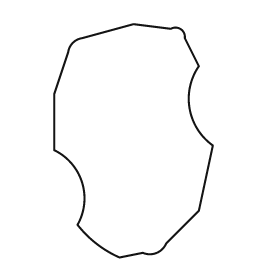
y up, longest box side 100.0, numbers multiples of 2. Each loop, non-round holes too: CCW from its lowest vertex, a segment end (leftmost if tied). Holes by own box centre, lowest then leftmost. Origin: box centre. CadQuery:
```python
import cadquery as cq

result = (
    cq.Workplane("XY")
    .moveTo(-6.0, -50.0)
    .lineTo(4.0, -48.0)
    .threePointArc((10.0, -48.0), (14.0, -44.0))
    .lineTo(28.0, -30.0)
    .lineTo(34.0, -2.0)
    .threePointArc((24.0, 14.0), (28.0, 32.0))
    .lineTo(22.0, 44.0)
    .threePointArc((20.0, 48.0), (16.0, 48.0))
    .lineTo(0.0, 50.0)
    .lineTo(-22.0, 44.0)
    .threePointArc((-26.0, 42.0), (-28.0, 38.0))
    .lineTo(-34.0, 20.0)
    .lineTo(-34.0, -4.0)
    .threePointArc((-22.0, -18.0), (-24.0, -36.0))
    .threePointArc((-16.0, -44.0), (-6.0, -50.0))
    .close()
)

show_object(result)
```